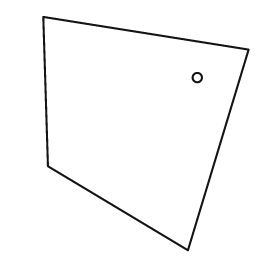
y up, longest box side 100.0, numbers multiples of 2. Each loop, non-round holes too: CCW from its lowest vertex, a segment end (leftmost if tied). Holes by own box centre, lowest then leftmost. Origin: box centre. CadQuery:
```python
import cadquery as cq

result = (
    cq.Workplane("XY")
    .moveTo(18.0, -50.0)
    .lineTo(44.0, 36.0)
    .lineTo(-44.0, 50.0)
    .lineTo(-42.0, -14.0)
    .close()
    .moveTo(22.0, 24.0)
    .circle(2.0)
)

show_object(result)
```